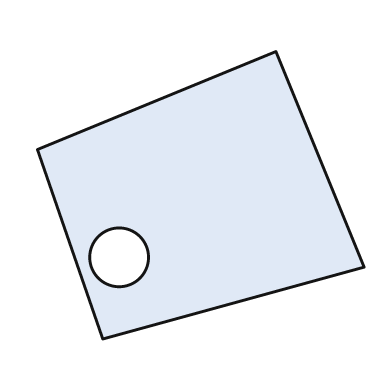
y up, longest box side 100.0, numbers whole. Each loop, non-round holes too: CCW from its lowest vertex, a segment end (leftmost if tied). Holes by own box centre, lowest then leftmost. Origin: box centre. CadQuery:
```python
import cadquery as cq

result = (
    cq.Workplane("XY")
    .moveTo(-30.0, -44.0)
    .lineTo(50.0, -22.0)
    .lineTo(23.0, 44.0)
    .lineTo(-50.0, 14.0)
    .close()
    .moveTo(-25.0, -19.0)
    .circle(9.0)
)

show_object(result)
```